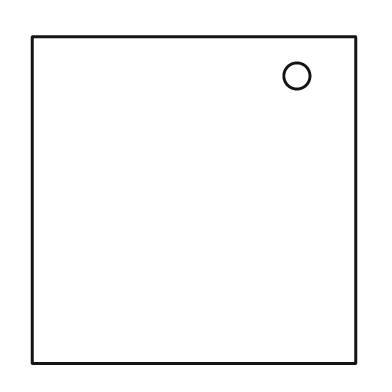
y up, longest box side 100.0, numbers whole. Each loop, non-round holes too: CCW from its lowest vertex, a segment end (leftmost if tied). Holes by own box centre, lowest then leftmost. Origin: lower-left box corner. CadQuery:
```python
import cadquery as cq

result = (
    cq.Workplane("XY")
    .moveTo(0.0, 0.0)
    .lineTo(99.0, 0.0)
    .lineTo(99.0, 100.0)
    .lineTo(0.0, 100.0)
    .close()
    .moveTo(81.0, 88.0)
    .circle(4.0)
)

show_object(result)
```